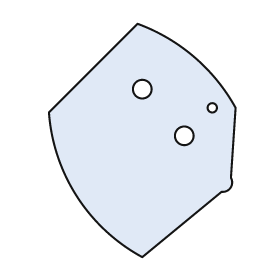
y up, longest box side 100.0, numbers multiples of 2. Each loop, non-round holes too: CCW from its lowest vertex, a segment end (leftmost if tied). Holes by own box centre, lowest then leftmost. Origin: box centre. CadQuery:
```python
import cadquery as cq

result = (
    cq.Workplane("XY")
    .moveTo(0.0, -50.0)
    .lineTo(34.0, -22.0)
    .threePointArc((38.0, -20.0), (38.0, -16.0))
    .lineTo(40.0, 14.0)
    .threePointArc((22.0, 36.0), (-2.0, 50.0))
    .lineTo(-40.0, 12.0)
    .threePointArc((-28.0, -24.0), (0.0, -50.0))
    .close()
    .moveTo(18.0, 2.0)
    .circle(4.0)
    .moveTo(30.0, 14.0)
    .circle(2.0)
    .moveTo(0.0, 22.0)
    .circle(4.0)
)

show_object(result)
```